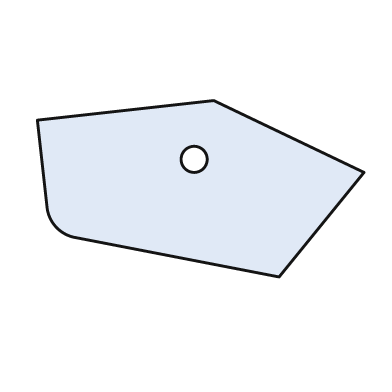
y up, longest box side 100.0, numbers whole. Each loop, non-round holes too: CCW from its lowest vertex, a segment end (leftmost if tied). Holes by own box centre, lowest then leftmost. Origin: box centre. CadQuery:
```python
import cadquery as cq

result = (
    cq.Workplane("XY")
    .moveTo(24.0, -27.0)
    .lineTo(50.0, 5.0)
    .lineTo(4.0, 27.0)
    .lineTo(-50.0, 21.0)
    .lineTo(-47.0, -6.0)
    .threePointArc((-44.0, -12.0), (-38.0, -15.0))
    .close()
    .moveTo(-2.0, 9.0)
    .circle(4.0)
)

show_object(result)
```